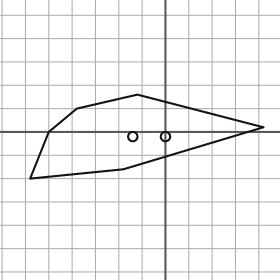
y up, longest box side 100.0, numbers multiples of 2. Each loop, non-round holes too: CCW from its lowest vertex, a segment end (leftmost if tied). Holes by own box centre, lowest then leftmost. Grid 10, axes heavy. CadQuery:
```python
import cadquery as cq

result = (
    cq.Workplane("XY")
    .moveTo(-58.0, -20.0)
    .lineTo(-18.0, -16.0)
    .lineTo(42.0, 2.0)
    .lineTo(-12.0, 16.0)
    .lineTo(-38.0, 10.0)
    .lineTo(-50.0, 0.0)
    .close()
    .moveTo(-14.0, -2.0)
    .circle(2.0)
    .moveTo(0.0, -2.0)
    .circle(2.0)
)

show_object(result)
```